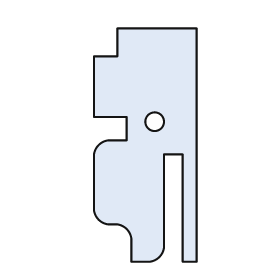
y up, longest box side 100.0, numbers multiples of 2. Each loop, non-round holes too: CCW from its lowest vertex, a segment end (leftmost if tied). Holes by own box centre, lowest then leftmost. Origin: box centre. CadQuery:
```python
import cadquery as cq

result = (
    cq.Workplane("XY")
    .moveTo(-6.0, -50.0)
    .lineTo(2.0, -50.0)
    .threePointArc((6.0, -48.0), (8.0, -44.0))
    .lineTo(8.0, -4.0)
    .lineTo(16.0, -4.0)
    .lineTo(16.0, -50.0)
    .lineTo(22.0, -50.0)
    .lineTo(22.0, 50.0)
    .lineTo(-12.0, 50.0)
    .lineTo(-12.0, 38.0)
    .lineTo(-22.0, 38.0)
    .lineTo(-22.0, 12.0)
    .lineTo(-8.0, 12.0)
    .lineTo(-8.0, 2.0)
    .lineTo(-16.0, 2.0)
    .threePointArc((-20.0, 0.0), (-22.0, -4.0))
    .lineTo(-22.0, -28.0)
    .threePointArc((-20.0, -32.0), (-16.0, -34.0))
    .lineTo(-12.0, -34.0)
    .threePointArc((-8.0, -36.0), (-6.0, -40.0))
    .close()
    .moveTo(4.0, 10.0)
    .circle(4.0)
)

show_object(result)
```